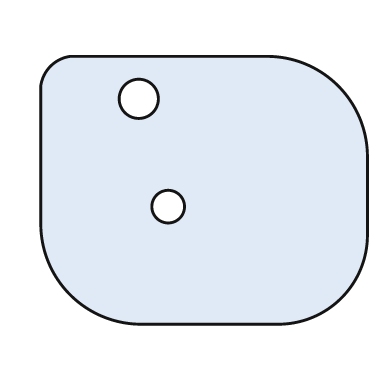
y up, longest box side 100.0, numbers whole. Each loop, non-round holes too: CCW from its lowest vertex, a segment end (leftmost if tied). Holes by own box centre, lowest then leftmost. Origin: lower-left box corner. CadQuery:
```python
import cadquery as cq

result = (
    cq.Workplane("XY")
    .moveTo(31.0, 0.0)
    .lineTo(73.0, 0.0)
    .threePointArc((92.0, 8.0), (100.0, 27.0))
    .lineTo(100.0, 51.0)
    .threePointArc((91.0, 73.0), (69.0, 82.0))
    .lineTo(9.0, 82.0)
    .threePointArc((3.0, 79.0), (0.0, 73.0))
    .lineTo(0.0, 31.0)
    .threePointArc((9.0, 9.0), (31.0, 0.0))
    .close()
    .moveTo(39.0, 36.0)
    .circle(5.0)
    .moveTo(30.0, 69.0)
    .circle(6.0)
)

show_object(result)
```